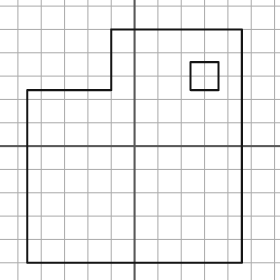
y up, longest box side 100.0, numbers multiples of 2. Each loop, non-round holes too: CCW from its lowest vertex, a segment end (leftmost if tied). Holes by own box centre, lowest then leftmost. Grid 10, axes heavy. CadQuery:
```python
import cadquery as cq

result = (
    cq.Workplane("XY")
    .moveTo(-46.0, -50.0)
    .lineTo(46.0, -50.0)
    .lineTo(46.0, 50.0)
    .lineTo(-10.0, 50.0)
    .lineTo(-10.0, 24.0)
    .lineTo(-46.0, 24.0)
    .close()
    .moveTo(24.0, 24.0)
    .lineTo(36.0, 24.0)
    .lineTo(36.0, 36.0)
    .lineTo(24.0, 36.0)
    .close()
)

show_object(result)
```